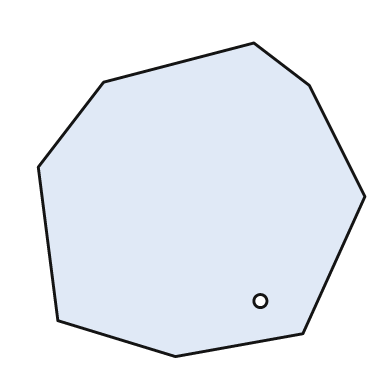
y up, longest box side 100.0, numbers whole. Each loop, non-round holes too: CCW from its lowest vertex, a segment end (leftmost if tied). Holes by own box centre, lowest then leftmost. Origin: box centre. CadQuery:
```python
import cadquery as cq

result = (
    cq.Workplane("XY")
    .moveTo(-8.0, -48.0)
    .lineTo(31.0, -41.0)
    .lineTo(50.0, 1.0)
    .lineTo(33.0, 35.0)
    .lineTo(16.0, 48.0)
    .lineTo(-30.0, 36.0)
    .lineTo(-50.0, 10.0)
    .lineTo(-44.0, -37.0)
    .close()
    .moveTo(18.0, -31.0)
    .circle(2.0)
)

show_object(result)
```